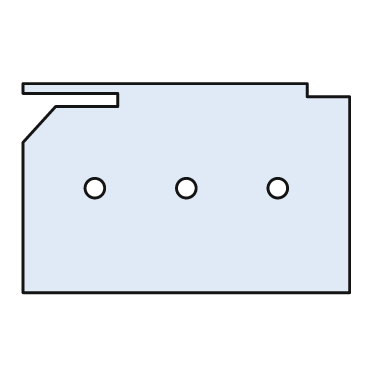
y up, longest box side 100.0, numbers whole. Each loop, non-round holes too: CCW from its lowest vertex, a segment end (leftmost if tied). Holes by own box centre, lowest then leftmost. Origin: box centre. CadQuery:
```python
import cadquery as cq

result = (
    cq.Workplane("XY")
    .moveTo(-50.0, -32.0)
    .lineTo(50.0, -32.0)
    .lineTo(50.0, 28.0)
    .lineTo(37.0, 28.0)
    .lineTo(37.0, 32.0)
    .lineTo(-50.0, 32.0)
    .lineTo(-50.0, 29.0)
    .lineTo(-21.0, 29.0)
    .lineTo(-21.0, 25.0)
    .lineTo(-40.0, 25.0)
    .lineTo(-50.0, 14.0)
    .close()
    .moveTo(-28.0, 0.0)
    .circle(3.0)
    .moveTo(0.0, 0.0)
    .circle(3.0)
    .moveTo(28.0, 0.0)
    .circle(3.0)
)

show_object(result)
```